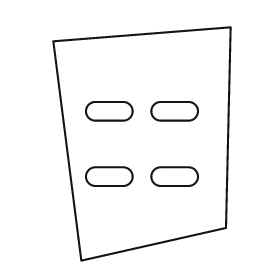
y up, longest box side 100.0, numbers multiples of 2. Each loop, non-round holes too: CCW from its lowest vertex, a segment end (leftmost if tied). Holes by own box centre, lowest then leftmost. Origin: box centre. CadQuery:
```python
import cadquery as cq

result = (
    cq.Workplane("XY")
    .moveTo(-26.0, -50.0)
    .lineTo(36.0, -36.0)
    .lineTo(38.0, 50.0)
    .lineTo(-38.0, 44.0)
    .close()
    .moveTo(-20.0, -18.0)
    .lineTo(-8.0, -18.0)
    .threePointArc((-4.0, -14.0), (-8.0, -10.0))
    .lineTo(-20.0, -10.0)
    .threePointArc((-24.0, -14.0), (-20.0, -18.0))
    .close()
    .moveTo(8.0, -18.0)
    .lineTo(20.0, -18.0)
    .threePointArc((24.0, -14.0), (20.0, -10.0))
    .lineTo(8.0, -10.0)
    .threePointArc((4.0, -14.0), (8.0, -18.0))
    .close()
    .moveTo(-20.0, 10.0)
    .lineTo(-8.0, 10.0)
    .threePointArc((-4.0, 14.0), (-8.0, 18.0))
    .lineTo(-20.0, 18.0)
    .threePointArc((-24.0, 14.0), (-20.0, 10.0))
    .close()
    .moveTo(8.0, 10.0)
    .lineTo(20.0, 10.0)
    .threePointArc((24.0, 14.0), (20.0, 18.0))
    .lineTo(8.0, 18.0)
    .threePointArc((4.0, 14.0), (8.0, 10.0))
    .close()
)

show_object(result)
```